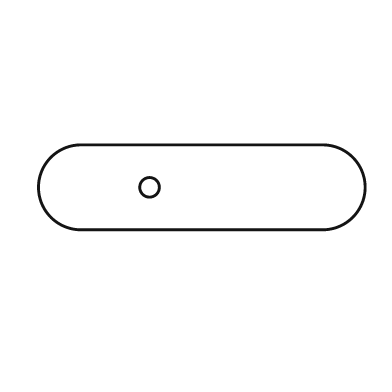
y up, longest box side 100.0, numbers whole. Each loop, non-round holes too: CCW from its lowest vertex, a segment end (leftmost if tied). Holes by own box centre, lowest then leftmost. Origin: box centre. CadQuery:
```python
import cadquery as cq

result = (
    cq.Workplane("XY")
    .moveTo(-37.0, -13.0)
    .lineTo(37.0, -13.0)
    .threePointArc((50.0, 0.0), (37.0, 13.0))
    .lineTo(-37.0, 13.0)
    .threePointArc((-50.0, 0.0), (-37.0, -13.0))
    .close()
    .moveTo(-16.0, 0.0)
    .circle(3.0)
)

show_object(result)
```